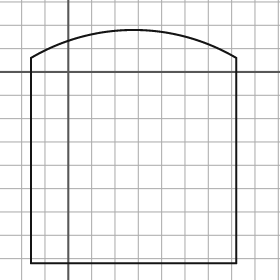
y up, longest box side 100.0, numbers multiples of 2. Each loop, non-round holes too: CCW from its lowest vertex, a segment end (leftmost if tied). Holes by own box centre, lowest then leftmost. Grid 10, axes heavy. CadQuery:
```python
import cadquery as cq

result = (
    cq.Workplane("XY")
    .moveTo(-16.0, -82.0)
    .lineTo(72.0, -82.0)
    .lineTo(72.0, 6.0)
    .threePointArc((28.0, 18.0), (-16.0, 6.0))
    .close()
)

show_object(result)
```